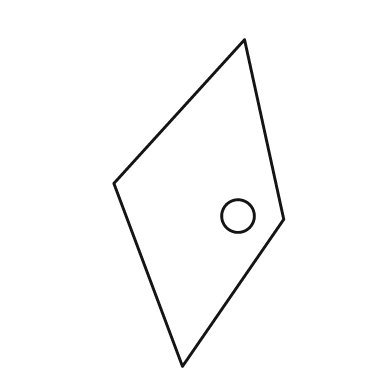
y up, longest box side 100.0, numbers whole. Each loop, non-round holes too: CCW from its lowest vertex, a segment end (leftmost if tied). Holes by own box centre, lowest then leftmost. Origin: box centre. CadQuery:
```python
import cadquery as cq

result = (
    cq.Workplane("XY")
    .moveTo(-5.0, -50.0)
    .lineTo(26.0, -5.0)
    .lineTo(14.0, 50.0)
    .lineTo(-26.0, 6.0)
    .close()
    .moveTo(12.0, -4.0)
    .circle(5.0)
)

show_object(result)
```